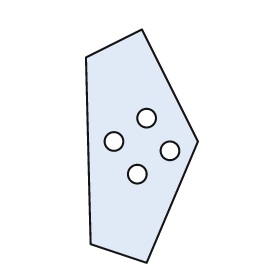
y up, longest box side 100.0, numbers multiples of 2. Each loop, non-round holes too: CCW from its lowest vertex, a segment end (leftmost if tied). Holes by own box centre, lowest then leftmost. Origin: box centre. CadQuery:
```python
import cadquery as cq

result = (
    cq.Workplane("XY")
    .moveTo(2.0, -50.0)
    .lineTo(24.0, 2.0)
    .lineTo(0.0, 50.0)
    .lineTo(-24.0, 38.0)
    .lineTo(-22.0, -42.0)
    .close()
    .moveTo(-2.0, -12.0)
    .circle(4.0)
    .moveTo(12.0, -2.0)
    .circle(4.0)
    .moveTo(-12.0, 2.0)
    .circle(4.0)
    .moveTo(2.0, 12.0)
    .circle(4.0)
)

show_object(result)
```